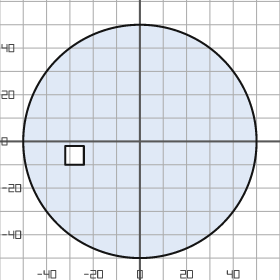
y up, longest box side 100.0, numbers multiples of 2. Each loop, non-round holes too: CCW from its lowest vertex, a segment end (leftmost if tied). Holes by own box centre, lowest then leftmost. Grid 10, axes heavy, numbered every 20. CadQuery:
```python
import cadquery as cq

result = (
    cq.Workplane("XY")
    .moveTo(0.0, 0.0)
    .circle(50.0)
    .moveTo(-32.0, -10.0)
    .lineTo(-24.0, -10.0)
    .lineTo(-24.0, -2.0)
    .lineTo(-32.0, -2.0)
    .close()
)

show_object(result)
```